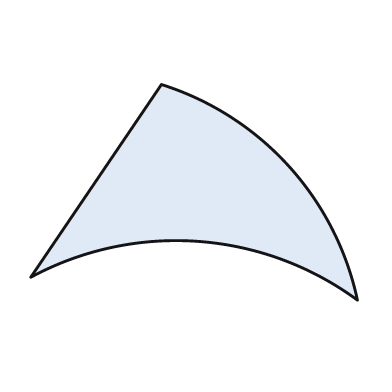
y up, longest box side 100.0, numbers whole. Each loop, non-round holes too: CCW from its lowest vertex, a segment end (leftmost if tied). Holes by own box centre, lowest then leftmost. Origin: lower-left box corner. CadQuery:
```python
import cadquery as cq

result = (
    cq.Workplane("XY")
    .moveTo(100.0, 0.0)
    .threePointArc((79.0, 41.0), (40.0, 66.0))
    .lineTo(0.0, 7.0)
    .threePointArc((51.0, 18.0), (100.0, 0.0))
    .close()
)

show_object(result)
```